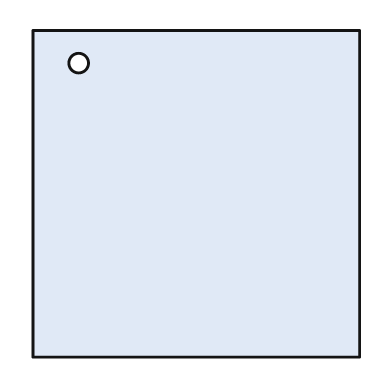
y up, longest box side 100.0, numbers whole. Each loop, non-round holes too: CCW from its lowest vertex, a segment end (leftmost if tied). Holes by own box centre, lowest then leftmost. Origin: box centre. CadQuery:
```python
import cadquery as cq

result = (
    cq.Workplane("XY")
    .moveTo(-50.0, -50.0)
    .lineTo(50.0, -50.0)
    .lineTo(50.0, 50.0)
    .lineTo(-50.0, 50.0)
    .close()
    .moveTo(-36.0, 40.0)
    .circle(3.0)
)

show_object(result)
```